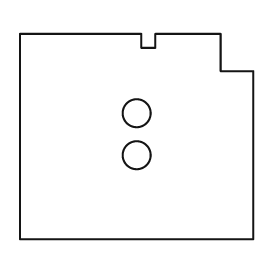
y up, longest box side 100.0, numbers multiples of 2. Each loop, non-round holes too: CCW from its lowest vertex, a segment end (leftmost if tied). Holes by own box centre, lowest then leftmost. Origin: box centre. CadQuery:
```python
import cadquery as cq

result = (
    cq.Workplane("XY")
    .moveTo(-50.0, -44.0)
    .lineTo(50.0, -44.0)
    .lineTo(50.0, 28.0)
    .lineTo(36.0, 28.0)
    .lineTo(36.0, 44.0)
    .lineTo(8.0, 44.0)
    .lineTo(8.0, 38.0)
    .lineTo(2.0, 38.0)
    .lineTo(2.0, 44.0)
    .lineTo(-50.0, 44.0)
    .close()
    .moveTo(0.0, -8.0)
    .circle(6.0)
    .moveTo(0.0, 10.0)
    .circle(6.0)
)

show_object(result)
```